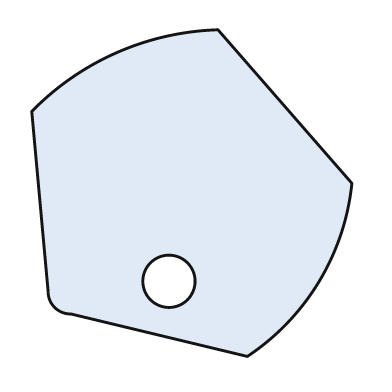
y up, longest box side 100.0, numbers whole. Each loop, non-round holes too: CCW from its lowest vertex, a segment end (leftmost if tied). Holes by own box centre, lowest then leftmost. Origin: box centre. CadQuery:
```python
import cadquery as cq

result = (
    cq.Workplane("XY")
    .moveTo(17.0, -50.0)
    .threePointArc((39.0, -27.0), (49.0, 3.0))
    .lineTo(8.0, 50.0)
    .threePointArc((-23.0, 43.0), (-49.0, 25.0))
    .lineTo(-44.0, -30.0)
    .threePointArc((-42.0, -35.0), (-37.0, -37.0))
    .close()
    .moveTo(-7.0, -27.0)
    .circle(8.0)
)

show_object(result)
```